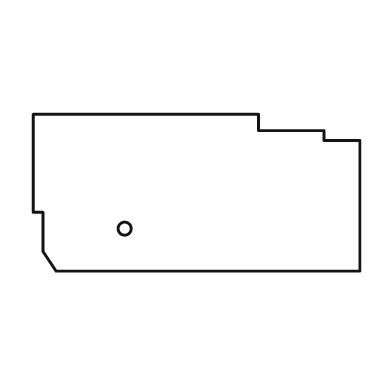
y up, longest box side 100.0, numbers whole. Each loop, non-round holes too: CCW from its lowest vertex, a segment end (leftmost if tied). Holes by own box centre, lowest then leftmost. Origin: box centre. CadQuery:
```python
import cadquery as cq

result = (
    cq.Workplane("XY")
    .moveTo(-43.0, -24.0)
    .lineTo(50.0, -24.0)
    .lineTo(50.0, 16.0)
    .lineTo(39.0, 16.0)
    .lineTo(39.0, 19.0)
    .lineTo(19.0, 19.0)
    .lineTo(19.0, 24.0)
    .lineTo(-50.0, 24.0)
    .lineTo(-50.0, -6.0)
    .lineTo(-47.0, -6.0)
    .lineTo(-47.0, -18.0)
    .close()
    .moveTo(-22.0, -11.0)
    .circle(2.0)
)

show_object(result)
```